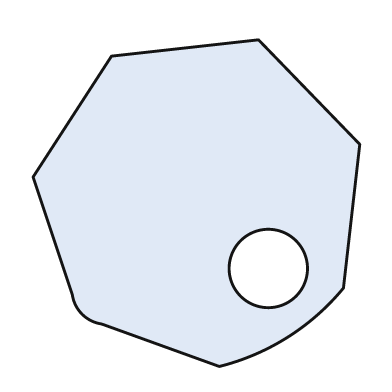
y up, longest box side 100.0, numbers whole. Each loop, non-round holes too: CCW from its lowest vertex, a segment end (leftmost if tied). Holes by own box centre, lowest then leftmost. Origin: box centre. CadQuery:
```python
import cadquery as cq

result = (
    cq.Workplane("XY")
    .moveTo(7.0, -50.0)
    .threePointArc((28.0, -41.0), (45.0, -26.0))
    .lineTo(50.0, 18.0)
    .lineTo(19.0, 50.0)
    .lineTo(-26.0, 45.0)
    .lineTo(-50.0, 8.0)
    .lineTo(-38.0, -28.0)
    .threePointArc((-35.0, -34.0), (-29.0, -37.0))
    .close()
    .moveTo(22.0, -20.0)
    .circle(12.0)
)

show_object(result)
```